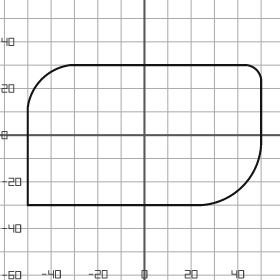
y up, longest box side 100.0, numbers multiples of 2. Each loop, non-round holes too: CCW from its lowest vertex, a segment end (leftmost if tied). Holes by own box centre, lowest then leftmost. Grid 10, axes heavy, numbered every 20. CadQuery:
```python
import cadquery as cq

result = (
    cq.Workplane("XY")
    .moveTo(-50.0, -30.0)
    .lineTo(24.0, -30.0)
    .threePointArc((42.0, -22.0), (50.0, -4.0))
    .lineTo(50.0, 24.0)
    .threePointArc((48.0, 28.0), (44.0, 30.0))
    .lineTo(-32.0, 30.0)
    .threePointArc((-44.0, 24.0), (-50.0, 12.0))
    .close()
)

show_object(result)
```